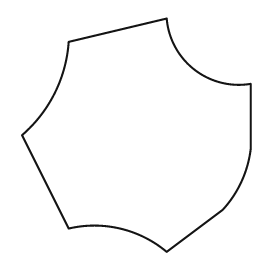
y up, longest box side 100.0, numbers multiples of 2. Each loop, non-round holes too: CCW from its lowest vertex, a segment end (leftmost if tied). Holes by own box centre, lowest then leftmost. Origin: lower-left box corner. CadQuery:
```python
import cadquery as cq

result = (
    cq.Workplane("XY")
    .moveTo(62.0, 0.0)
    .lineTo(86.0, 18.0)
    .threePointArc((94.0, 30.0), (98.0, 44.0))
    .lineTo(98.0, 72.0)
    .threePointArc((74.0, 78.0), (62.0, 100.0))
    .lineTo(20.0, 90.0)
    .threePointArc((14.0, 68.0), (0.0, 50.0))
    .lineTo(20.0, 10.0)
    .threePointArc((42.0, 10.0), (62.0, 0.0))
    .close()
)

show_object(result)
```